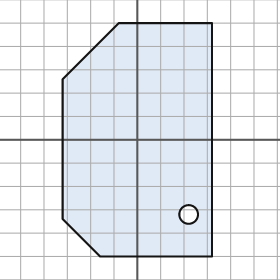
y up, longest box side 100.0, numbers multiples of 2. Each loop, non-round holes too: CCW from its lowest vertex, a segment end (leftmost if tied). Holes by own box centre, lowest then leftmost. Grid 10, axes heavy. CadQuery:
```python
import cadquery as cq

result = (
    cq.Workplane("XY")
    .moveTo(-16.0, -50.0)
    .lineTo(32.0, -50.0)
    .lineTo(32.0, 50.0)
    .lineTo(-8.0, 50.0)
    .lineTo(-32.0, 26.0)
    .lineTo(-32.0, -34.0)
    .close()
    .moveTo(22.0, -32.0)
    .circle(4.0)
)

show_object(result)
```